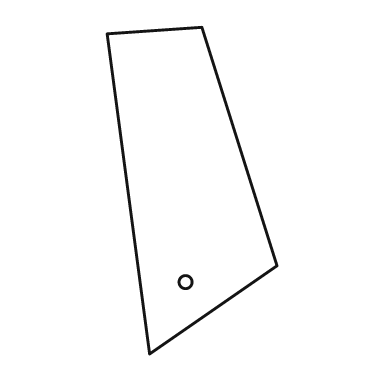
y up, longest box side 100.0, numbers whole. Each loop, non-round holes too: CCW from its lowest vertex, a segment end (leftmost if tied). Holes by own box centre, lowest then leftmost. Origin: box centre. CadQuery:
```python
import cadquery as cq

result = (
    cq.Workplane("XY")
    .moveTo(-13.0, -50.0)
    .lineTo(26.0, -23.0)
    .lineTo(3.0, 50.0)
    .lineTo(-26.0, 48.0)
    .close()
    .moveTo(-2.0, -28.0)
    .circle(2.0)
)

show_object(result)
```